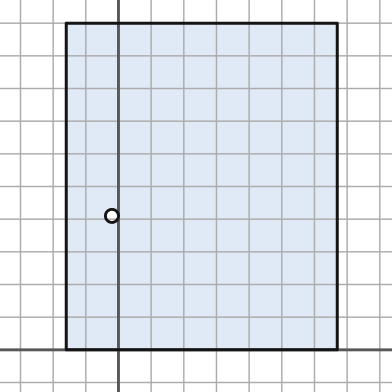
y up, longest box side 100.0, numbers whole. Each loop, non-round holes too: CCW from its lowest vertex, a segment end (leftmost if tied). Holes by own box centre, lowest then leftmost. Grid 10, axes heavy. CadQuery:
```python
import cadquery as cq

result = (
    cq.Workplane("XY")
    .moveTo(-16.0, 0.0)
    .lineTo(67.0, 0.0)
    .lineTo(67.0, 100.0)
    .lineTo(-16.0, 100.0)
    .close()
    .moveTo(-2.0, 41.0)
    .circle(2.0)
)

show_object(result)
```